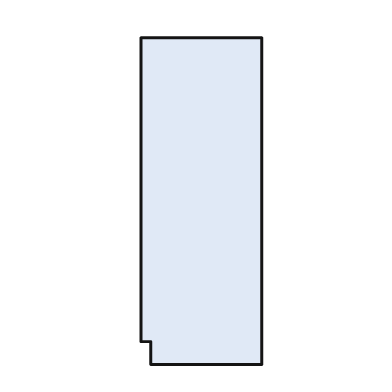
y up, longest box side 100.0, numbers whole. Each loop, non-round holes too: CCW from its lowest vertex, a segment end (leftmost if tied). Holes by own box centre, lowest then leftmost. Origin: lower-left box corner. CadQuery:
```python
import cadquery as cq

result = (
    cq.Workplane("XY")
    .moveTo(3.0, 0.0)
    .lineTo(37.0, 0.0)
    .lineTo(37.0, 100.0)
    .lineTo(0.0, 100.0)
    .lineTo(0.0, 7.0)
    .lineTo(3.0, 7.0)
    .close()
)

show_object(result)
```